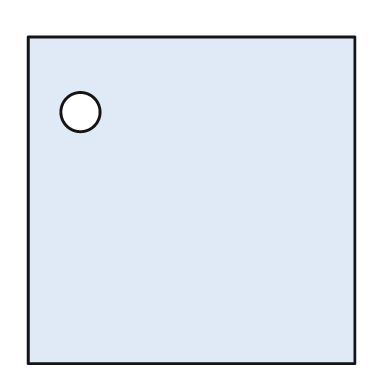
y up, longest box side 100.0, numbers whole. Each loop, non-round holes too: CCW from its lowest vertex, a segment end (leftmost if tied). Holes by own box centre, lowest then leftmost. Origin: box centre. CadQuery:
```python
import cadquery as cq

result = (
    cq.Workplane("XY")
    .moveTo(-50.0, -50.0)
    .lineTo(50.0, -50.0)
    .lineTo(50.0, 50.0)
    .lineTo(-50.0, 50.0)
    .close()
    .moveTo(-34.0, 27.0)
    .circle(6.0)
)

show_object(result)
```